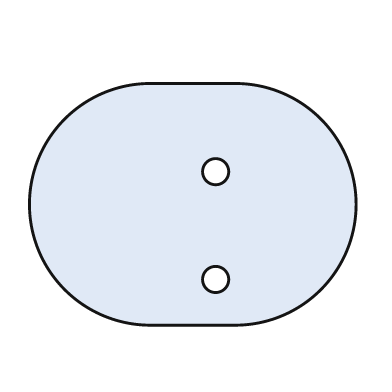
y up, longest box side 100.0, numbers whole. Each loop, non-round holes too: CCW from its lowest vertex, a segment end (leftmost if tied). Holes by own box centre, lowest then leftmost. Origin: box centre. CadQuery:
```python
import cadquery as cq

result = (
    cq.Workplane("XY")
    .moveTo(-13.0, -37.0)
    .lineTo(13.0, -37.0)
    .threePointArc((50.0, 0.0), (13.0, 37.0))
    .lineTo(-13.0, 37.0)
    .threePointArc((-50.0, 0.0), (-13.0, -37.0))
    .close()
    .moveTo(7.0, -23.0)
    .circle(4.0)
    .moveTo(7.0, 10.0)
    .circle(4.0)
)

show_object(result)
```